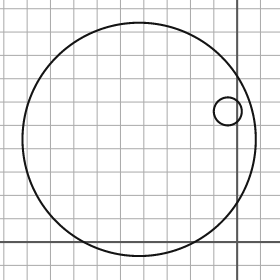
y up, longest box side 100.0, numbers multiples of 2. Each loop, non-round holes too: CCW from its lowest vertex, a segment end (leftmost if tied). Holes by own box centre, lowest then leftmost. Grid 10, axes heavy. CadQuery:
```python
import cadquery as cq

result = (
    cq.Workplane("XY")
    .moveTo(-42.0, 44.0)
    .circle(50.0)
    .moveTo(-4.0, 56.0)
    .circle(6.0)
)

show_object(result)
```